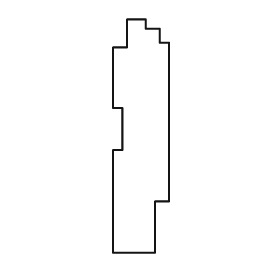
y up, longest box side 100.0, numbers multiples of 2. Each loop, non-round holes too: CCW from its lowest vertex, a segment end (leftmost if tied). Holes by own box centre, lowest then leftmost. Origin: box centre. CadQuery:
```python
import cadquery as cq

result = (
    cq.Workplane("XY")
    .moveTo(-12.0, -50.0)
    .lineTo(6.0, -50.0)
    .lineTo(6.0, -28.0)
    .lineTo(12.0, -28.0)
    .lineTo(12.0, 40.0)
    .lineTo(8.0, 40.0)
    .lineTo(8.0, 46.0)
    .lineTo(2.0, 46.0)
    .lineTo(2.0, 50.0)
    .lineTo(-6.0, 50.0)
    .lineTo(-6.0, 38.0)
    .lineTo(-12.0, 38.0)
    .lineTo(-12.0, 12.0)
    .lineTo(-8.0, 12.0)
    .lineTo(-8.0, -6.0)
    .lineTo(-12.0, -6.0)
    .close()
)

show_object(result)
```